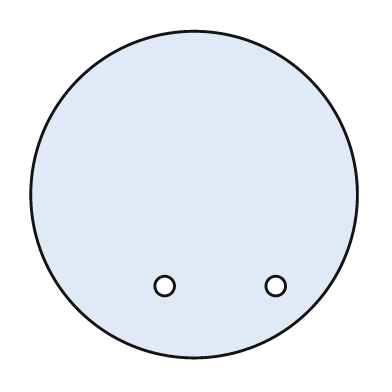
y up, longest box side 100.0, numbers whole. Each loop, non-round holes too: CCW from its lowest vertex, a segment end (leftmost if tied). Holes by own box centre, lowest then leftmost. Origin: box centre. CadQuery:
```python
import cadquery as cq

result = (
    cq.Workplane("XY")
    .moveTo(0.0, 0.0)
    .circle(50.0)
    .moveTo(-9.0, -28.0)
    .circle(3.0)
    .moveTo(25.0, -28.0)
    .circle(3.0)
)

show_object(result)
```